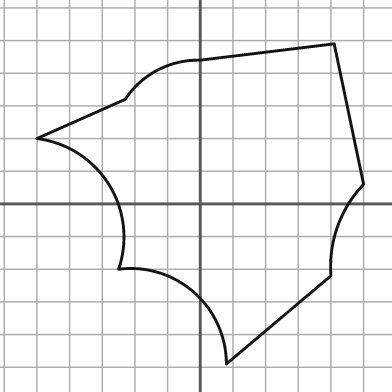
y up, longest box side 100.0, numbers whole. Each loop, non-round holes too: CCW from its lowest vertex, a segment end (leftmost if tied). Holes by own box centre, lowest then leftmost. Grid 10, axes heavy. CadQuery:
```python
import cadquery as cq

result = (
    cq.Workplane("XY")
    .moveTo(8.0, -49.0)
    .lineTo(40.0, -22.0)
    .threePointArc((42.0, -7.0), (50.0, 6.0))
    .lineTo(41.0, 49.0)
    .lineTo(0.0, 44.0)
    .threePointArc((-13.0, 41.0), (-23.0, 32.0))
    .lineTo(-50.0, 20.0)
    .threePointArc((-28.0, 6.0), (-25.0, -20.0))
    .threePointArc((-2.0, -27.0), (8.0, -49.0))
    .close()
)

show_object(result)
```